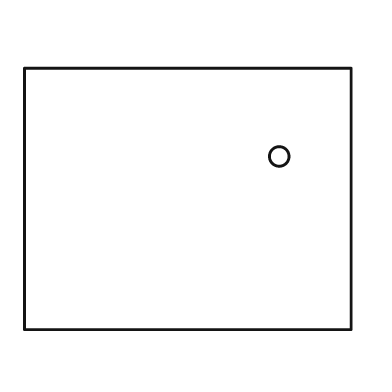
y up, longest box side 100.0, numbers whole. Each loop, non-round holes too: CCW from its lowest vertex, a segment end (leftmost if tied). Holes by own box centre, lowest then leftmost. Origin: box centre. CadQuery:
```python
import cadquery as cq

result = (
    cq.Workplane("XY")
    .moveTo(-50.0, -40.0)
    .lineTo(50.0, -40.0)
    .lineTo(50.0, 40.0)
    .lineTo(-50.0, 40.0)
    .close()
    .moveTo(28.0, 13.0)
    .circle(3.0)
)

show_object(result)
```